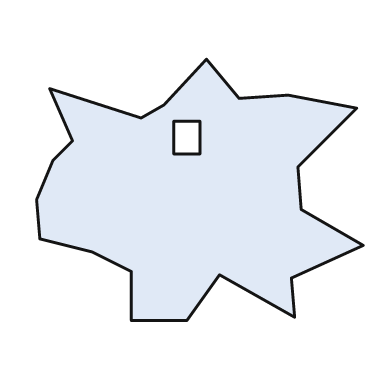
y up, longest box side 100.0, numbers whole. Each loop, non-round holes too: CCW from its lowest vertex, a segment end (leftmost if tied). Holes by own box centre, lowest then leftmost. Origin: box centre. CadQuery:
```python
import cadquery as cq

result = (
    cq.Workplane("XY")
    .moveTo(-21.0, -40.0)
    .lineTo(-4.0, -40.0)
    .lineTo(6.0, -26.0)
    .lineTo(29.0, -39.0)
    .lineTo(28.0, -27.0)
    .lineTo(50.0, -17.0)
    .lineTo(31.0, -6.0)
    .lineTo(30.0, 7.0)
    .lineTo(48.0, 25.0)
    .lineTo(27.0, 29.0)
    .lineTo(12.0, 28.0)
    .lineTo(2.0, 40.0)
    .lineTo(-11.0, 26.0)
    .lineTo(-18.0, 22.0)
    .lineTo(-46.0, 31.0)
    .lineTo(-39.0, 15.0)
    .lineTo(-45.0, 9.0)
    .lineTo(-50.0, -3.0)
    .lineTo(-49.0, -15.0)
    .lineTo(-33.0, -19.0)
    .lineTo(-21.0, -25.0)
    .close()
    .moveTo(-8.0, 11.0)
    .lineTo(0.0, 11.0)
    .lineTo(0.0, 21.0)
    .lineTo(-8.0, 21.0)
    .close()
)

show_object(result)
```